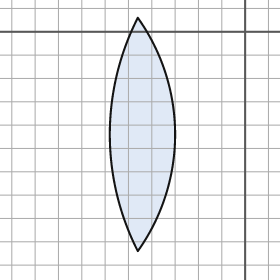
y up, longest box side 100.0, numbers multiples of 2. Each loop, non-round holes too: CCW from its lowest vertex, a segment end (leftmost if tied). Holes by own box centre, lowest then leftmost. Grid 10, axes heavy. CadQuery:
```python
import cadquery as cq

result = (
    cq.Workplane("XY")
    .moveTo(-46.0, -94.0)
    .threePointArc((-30.0, -44.0), (-46.0, 6.0))
    .threePointArc((-58.0, -44.0), (-46.0, -94.0))
    .close()
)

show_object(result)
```